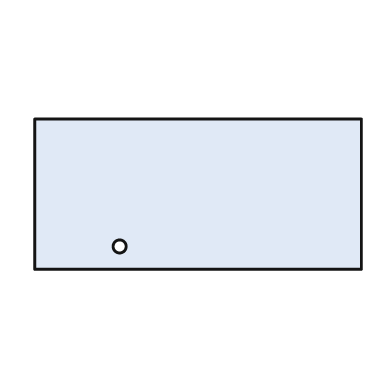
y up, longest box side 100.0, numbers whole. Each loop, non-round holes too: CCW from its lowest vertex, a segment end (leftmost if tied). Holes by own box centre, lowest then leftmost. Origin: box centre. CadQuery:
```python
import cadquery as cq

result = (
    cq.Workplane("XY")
    .moveTo(-50.0, -23.0)
    .lineTo(50.0, -23.0)
    .lineTo(50.0, 23.0)
    .lineTo(-50.0, 23.0)
    .close()
    .moveTo(-24.0, -16.0)
    .circle(2.0)
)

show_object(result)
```